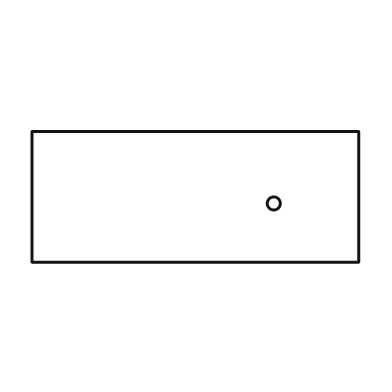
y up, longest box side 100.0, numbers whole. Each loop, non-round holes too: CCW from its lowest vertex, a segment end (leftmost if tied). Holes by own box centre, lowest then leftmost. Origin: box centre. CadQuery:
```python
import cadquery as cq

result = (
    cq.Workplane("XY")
    .moveTo(-50.0, -20.0)
    .lineTo(50.0, -20.0)
    .lineTo(50.0, 20.0)
    .lineTo(-50.0, 20.0)
    .close()
    .moveTo(24.0, -2.0)
    .circle(2.0)
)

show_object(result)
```